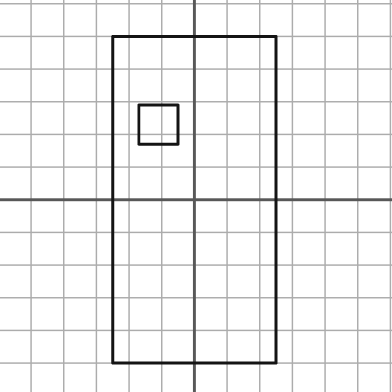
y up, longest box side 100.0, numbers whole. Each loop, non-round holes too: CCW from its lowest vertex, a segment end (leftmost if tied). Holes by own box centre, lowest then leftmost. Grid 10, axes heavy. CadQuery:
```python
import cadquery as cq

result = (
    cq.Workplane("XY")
    .moveTo(-25.0, -50.0)
    .lineTo(25.0, -50.0)
    .lineTo(25.0, 50.0)
    .lineTo(-25.0, 50.0)
    .close()
    .moveTo(-17.0, 17.0)
    .lineTo(-5.0, 17.0)
    .lineTo(-5.0, 29.0)
    .lineTo(-17.0, 29.0)
    .close()
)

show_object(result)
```